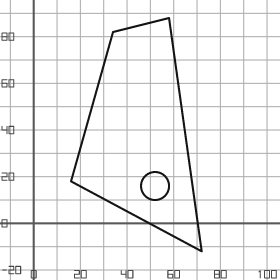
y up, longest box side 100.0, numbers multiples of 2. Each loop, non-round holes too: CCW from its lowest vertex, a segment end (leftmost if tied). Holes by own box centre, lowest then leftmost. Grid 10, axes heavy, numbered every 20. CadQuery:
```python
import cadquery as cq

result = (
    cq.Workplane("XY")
    .moveTo(72.0, -12.0)
    .lineTo(58.0, 88.0)
    .lineTo(34.0, 82.0)
    .lineTo(16.0, 18.0)
    .close()
    .moveTo(52.0, 16.0)
    .circle(6.0)
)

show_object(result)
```